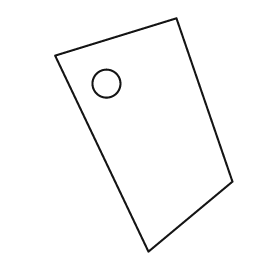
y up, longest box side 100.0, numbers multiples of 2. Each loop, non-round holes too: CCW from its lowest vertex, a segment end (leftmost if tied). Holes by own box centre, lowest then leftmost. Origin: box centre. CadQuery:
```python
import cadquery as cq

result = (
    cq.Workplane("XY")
    .moveTo(2.0, -50.0)
    .lineTo(38.0, -20.0)
    .lineTo(14.0, 50.0)
    .lineTo(-38.0, 34.0)
    .close()
    .moveTo(-16.0, 22.0)
    .circle(6.0)
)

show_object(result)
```